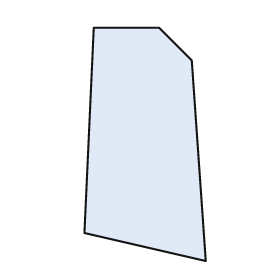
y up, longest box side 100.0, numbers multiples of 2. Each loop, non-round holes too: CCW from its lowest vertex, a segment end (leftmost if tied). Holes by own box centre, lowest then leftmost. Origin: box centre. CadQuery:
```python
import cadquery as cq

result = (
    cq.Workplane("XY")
    .moveTo(26.0, -50.0)
    .lineTo(20.0, 36.0)
    .lineTo(6.0, 50.0)
    .lineTo(-22.0, 50.0)
    .lineTo(-26.0, -38.0)
    .close()
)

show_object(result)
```